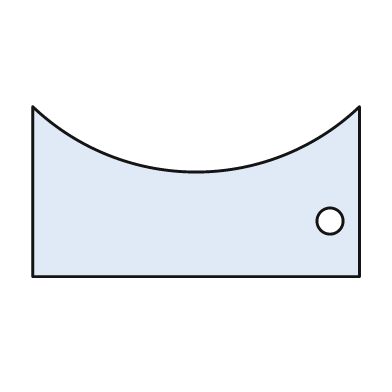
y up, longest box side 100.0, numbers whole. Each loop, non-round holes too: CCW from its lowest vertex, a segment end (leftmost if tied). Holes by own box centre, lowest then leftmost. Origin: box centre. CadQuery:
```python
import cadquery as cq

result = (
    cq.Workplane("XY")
    .moveTo(-50.0, -26.0)
    .lineTo(50.0, -26.0)
    .lineTo(50.0, 26.0)
    .threePointArc((0.0, 6.0), (-50.0, 26.0))
    .close()
    .moveTo(41.0, -9.0)
    .circle(4.0)
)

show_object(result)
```